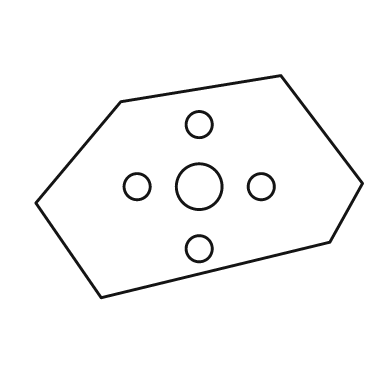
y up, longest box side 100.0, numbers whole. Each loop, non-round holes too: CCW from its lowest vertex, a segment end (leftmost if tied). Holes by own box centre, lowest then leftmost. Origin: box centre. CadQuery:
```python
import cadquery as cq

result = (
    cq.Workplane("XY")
    .moveTo(-30.0, -34.0)
    .lineTo(40.0, -17.0)
    .lineTo(50.0, 1.0)
    .lineTo(25.0, 34.0)
    .lineTo(-24.0, 26.0)
    .lineTo(-50.0, -5.0)
    .close()
    .moveTo(0.0, -19.0)
    .circle(4.0)
    .moveTo(-19.0, 0.0)
    .circle(4.0)
    .moveTo(0.0, 0.0)
    .circle(7.0)
    .moveTo(19.0, 0.0)
    .circle(4.0)
    .moveTo(0.0, 19.0)
    .circle(4.0)
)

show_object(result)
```